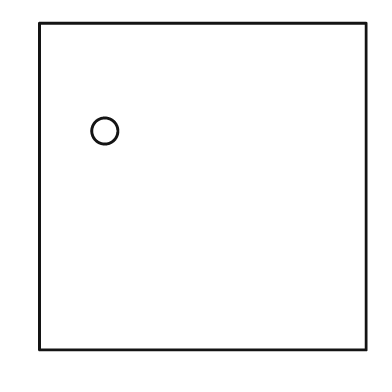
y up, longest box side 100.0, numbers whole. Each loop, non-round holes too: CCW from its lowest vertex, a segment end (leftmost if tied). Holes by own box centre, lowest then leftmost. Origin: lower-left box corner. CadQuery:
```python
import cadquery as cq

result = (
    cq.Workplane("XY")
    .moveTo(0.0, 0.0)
    .lineTo(100.0, 0.0)
    .lineTo(100.0, 100.0)
    .lineTo(0.0, 100.0)
    .close()
    .moveTo(20.0, 67.0)
    .circle(4.0)
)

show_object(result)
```